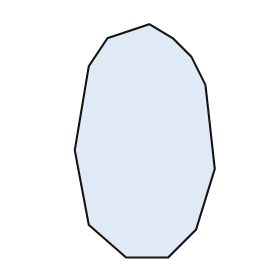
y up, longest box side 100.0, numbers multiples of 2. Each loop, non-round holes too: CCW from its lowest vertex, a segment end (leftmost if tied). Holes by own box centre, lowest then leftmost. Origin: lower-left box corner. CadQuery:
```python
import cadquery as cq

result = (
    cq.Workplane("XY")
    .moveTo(22.0, 0.0)
    .lineTo(40.0, 0.0)
    .lineTo(52.0, 12.0)
    .lineTo(60.0, 38.0)
    .lineTo(56.0, 74.0)
    .lineTo(50.0, 86.0)
    .lineTo(42.0, 94.0)
    .lineTo(32.0, 100.0)
    .lineTo(14.0, 94.0)
    .lineTo(6.0, 82.0)
    .lineTo(0.0, 46.0)
    .lineTo(6.0, 14.0)
    .close()
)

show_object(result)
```